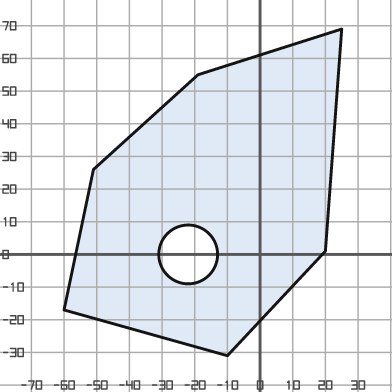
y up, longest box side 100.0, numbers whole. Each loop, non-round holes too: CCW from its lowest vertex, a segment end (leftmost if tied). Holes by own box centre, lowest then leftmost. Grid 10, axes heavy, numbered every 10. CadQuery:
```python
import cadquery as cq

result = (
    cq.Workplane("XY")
    .moveTo(-10.0, -31.0)
    .lineTo(20.0, 1.0)
    .lineTo(25.0, 69.0)
    .lineTo(-19.0, 55.0)
    .lineTo(-51.0, 26.0)
    .lineTo(-60.0, -17.0)
    .close()
    .moveTo(-22.0, 0.0)
    .circle(9.0)
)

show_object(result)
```